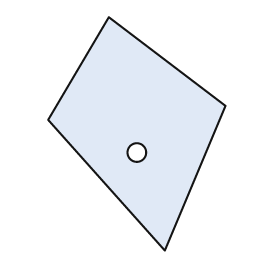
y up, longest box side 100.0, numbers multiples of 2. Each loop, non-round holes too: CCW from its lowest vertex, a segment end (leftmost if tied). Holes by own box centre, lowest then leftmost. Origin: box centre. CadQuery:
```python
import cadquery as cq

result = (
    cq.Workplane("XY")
    .moveTo(12.0, -50.0)
    .lineTo(38.0, 12.0)
    .lineTo(-12.0, 50.0)
    .lineTo(-38.0, 6.0)
    .close()
    .moveTo(0.0, -8.0)
    .circle(4.0)
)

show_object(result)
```